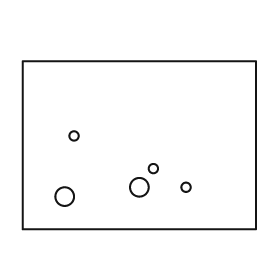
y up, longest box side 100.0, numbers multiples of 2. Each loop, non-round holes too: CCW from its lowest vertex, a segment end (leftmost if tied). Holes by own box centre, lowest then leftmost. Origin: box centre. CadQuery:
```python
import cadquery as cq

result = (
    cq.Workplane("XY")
    .moveTo(-50.0, -36.0)
    .lineTo(50.0, -36.0)
    .lineTo(50.0, 36.0)
    .lineTo(-50.0, 36.0)
    .close()
    .moveTo(-32.0, -22.0)
    .circle(4.0)
    .moveTo(0.0, -18.0)
    .circle(4.0)
    .moveTo(20.0, -18.0)
    .circle(2.0)
    .moveTo(6.0, -10.0)
    .circle(2.0)
    .moveTo(-28.0, 4.0)
    .circle(2.0)
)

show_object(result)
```